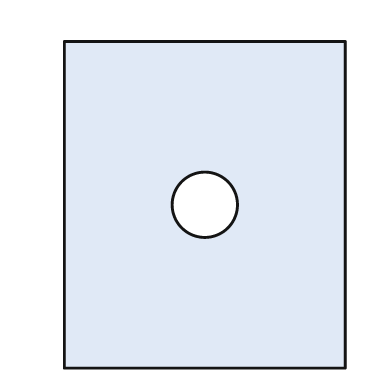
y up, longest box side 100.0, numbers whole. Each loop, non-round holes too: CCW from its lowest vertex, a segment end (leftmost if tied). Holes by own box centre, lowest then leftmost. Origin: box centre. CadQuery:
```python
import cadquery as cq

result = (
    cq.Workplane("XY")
    .moveTo(-43.0, -50.0)
    .lineTo(43.0, -50.0)
    .lineTo(43.0, 50.0)
    .lineTo(-43.0, 50.0)
    .close()
    .moveTo(0.0, 0.0)
    .circle(10.0)
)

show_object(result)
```